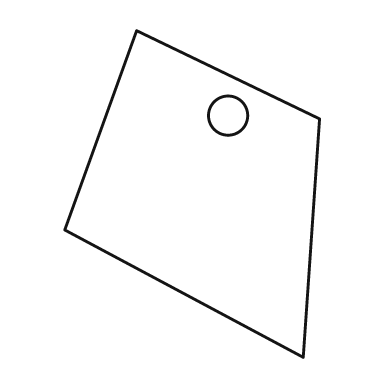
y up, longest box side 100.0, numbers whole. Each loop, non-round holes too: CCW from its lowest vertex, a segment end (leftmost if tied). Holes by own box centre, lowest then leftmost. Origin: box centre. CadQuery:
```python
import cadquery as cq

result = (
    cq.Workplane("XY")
    .moveTo(34.0, -50.0)
    .lineTo(39.0, 23.0)
    .lineTo(-17.0, 50.0)
    .lineTo(-39.0, -11.0)
    .close()
    .moveTo(11.0, 24.0)
    .circle(6.0)
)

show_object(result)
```